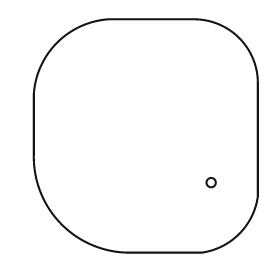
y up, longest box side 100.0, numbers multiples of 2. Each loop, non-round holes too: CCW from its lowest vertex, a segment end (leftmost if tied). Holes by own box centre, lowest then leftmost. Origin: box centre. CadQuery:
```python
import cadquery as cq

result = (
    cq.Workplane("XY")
    .moveTo(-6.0, -50.0)
    .lineTo(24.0, -50.0)
    .threePointArc((40.0, -42.0), (48.0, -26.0))
    .lineTo(48.0, 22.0)
    .threePointArc((40.0, 42.0), (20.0, 50.0))
    .lineTo(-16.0, 50.0)
    .threePointArc((-38.0, 40.0), (-48.0, 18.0))
    .lineTo(-48.0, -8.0)
    .threePointArc((-36.0, -38.0), (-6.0, -50.0))
    .close()
    .moveTo(28.0, -20.0)
    .circle(2.0)
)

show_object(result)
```